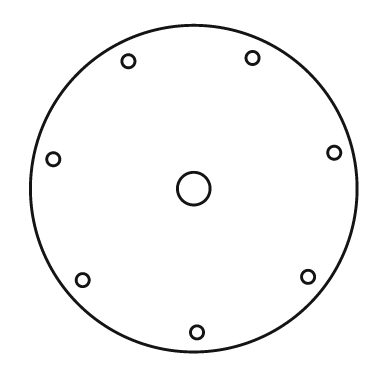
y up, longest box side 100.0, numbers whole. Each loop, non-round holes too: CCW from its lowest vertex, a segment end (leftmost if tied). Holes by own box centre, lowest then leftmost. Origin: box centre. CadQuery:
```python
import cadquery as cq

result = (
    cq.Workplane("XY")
    .moveTo(0.0, 0.0)
    .circle(50.0)
    .moveTo(1.0, -44.0)
    .circle(2.0)
    .moveTo(-34.0, -28.0)
    .circle(2.0)
    .moveTo(35.0, -27.0)
    .circle(2.0)
    .moveTo(0.0, 0.0)
    .circle(5.0)
    .moveTo(-43.0, 9.0)
    .circle(2.0)
    .moveTo(43.0, 11.0)
    .circle(2.0)
    .moveTo(-20.0, 39.0)
    .circle(2.0)
    .moveTo(18.0, 40.0)
    .circle(2.0)
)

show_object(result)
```